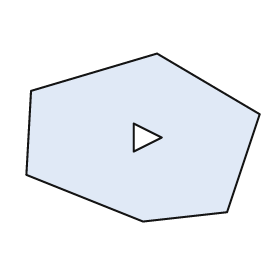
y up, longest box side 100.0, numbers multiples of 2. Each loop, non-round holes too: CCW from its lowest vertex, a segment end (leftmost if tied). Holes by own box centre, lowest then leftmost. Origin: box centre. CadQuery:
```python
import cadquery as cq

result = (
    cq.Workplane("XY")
    .moveTo(0.0, -36.0)
    .lineTo(36.0, -32.0)
    .lineTo(50.0, 10.0)
    .lineTo(6.0, 36.0)
    .lineTo(-48.0, 20.0)
    .lineTo(-50.0, -16.0)
    .close()
    .moveTo(-4.0, -6.0)
    .lineTo(8.0, 0.0)
    .lineTo(-4.0, 6.0)
    .close()
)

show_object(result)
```